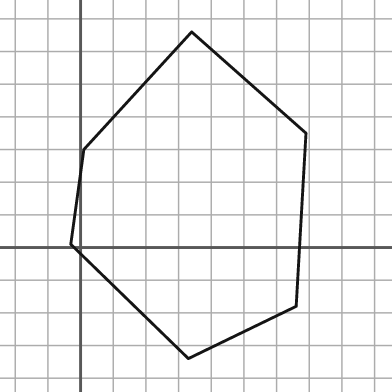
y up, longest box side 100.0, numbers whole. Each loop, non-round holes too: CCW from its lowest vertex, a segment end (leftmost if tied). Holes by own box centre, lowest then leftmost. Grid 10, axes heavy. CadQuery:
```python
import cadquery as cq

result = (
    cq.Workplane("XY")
    .moveTo(33.0, -34.0)
    .lineTo(66.0, -18.0)
    .lineTo(69.0, 35.0)
    .lineTo(34.0, 66.0)
    .lineTo(1.0, 30.0)
    .lineTo(-3.0, 1.0)
    .close()
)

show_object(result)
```